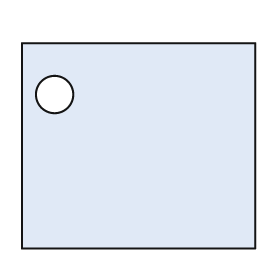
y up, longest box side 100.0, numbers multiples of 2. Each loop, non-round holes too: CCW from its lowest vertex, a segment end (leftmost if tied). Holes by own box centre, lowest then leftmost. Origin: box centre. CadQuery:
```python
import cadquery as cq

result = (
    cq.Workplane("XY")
    .moveTo(-50.0, -44.0)
    .lineTo(50.0, -44.0)
    .lineTo(50.0, 44.0)
    .lineTo(-50.0, 44.0)
    .close()
    .moveTo(-36.0, 22.0)
    .circle(8.0)
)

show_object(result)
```